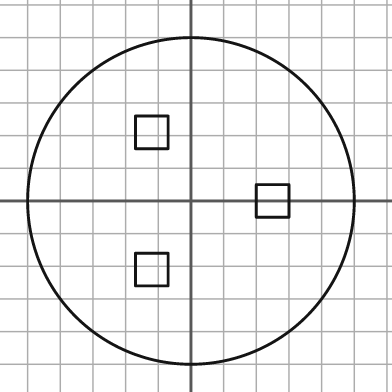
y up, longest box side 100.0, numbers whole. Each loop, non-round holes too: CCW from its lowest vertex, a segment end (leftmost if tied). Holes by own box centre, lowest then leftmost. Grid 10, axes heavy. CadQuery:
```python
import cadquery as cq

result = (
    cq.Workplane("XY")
    .moveTo(0.0, 0.0)
    .circle(50.0)
    .moveTo(-17.0, -26.0)
    .lineTo(-7.0, -26.0)
    .lineTo(-7.0, -16.0)
    .lineTo(-17.0, -16.0)
    .close()
    .moveTo(20.0, -5.0)
    .lineTo(30.0, -5.0)
    .lineTo(30.0, 5.0)
    .lineTo(20.0, 5.0)
    .close()
    .moveTo(-17.0, 16.0)
    .lineTo(-7.0, 16.0)
    .lineTo(-7.0, 26.0)
    .lineTo(-17.0, 26.0)
    .close()
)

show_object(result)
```